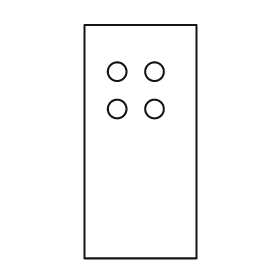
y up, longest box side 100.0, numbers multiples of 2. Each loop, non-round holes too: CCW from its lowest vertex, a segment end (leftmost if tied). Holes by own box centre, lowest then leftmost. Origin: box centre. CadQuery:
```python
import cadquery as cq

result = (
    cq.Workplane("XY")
    .moveTo(-24.0, -50.0)
    .lineTo(24.0, -50.0)
    .lineTo(24.0, 50.0)
    .lineTo(-24.0, 50.0)
    .close()
    .moveTo(-10.0, 14.0)
    .circle(4.0)
    .moveTo(6.0, 14.0)
    .circle(4.0)
    .moveTo(-10.0, 30.0)
    .circle(4.0)
    .moveTo(6.0, 30.0)
    .circle(4.0)
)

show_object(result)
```